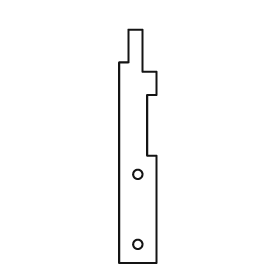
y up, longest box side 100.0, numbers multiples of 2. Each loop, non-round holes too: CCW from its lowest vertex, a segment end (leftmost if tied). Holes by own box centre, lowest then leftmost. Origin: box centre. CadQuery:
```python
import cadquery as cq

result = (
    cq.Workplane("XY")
    .moveTo(-8.0, -50.0)
    .lineTo(8.0, -50.0)
    .lineTo(8.0, -4.0)
    .lineTo(4.0, -4.0)
    .lineTo(4.0, 22.0)
    .lineTo(8.0, 22.0)
    .lineTo(8.0, 32.0)
    .lineTo(2.0, 32.0)
    .lineTo(2.0, 50.0)
    .lineTo(-4.0, 50.0)
    .lineTo(-4.0, 36.0)
    .lineTo(-8.0, 36.0)
    .close()
    .moveTo(0.0, -42.0)
    .circle(2.0)
    .moveTo(0.0, -12.0)
    .circle(2.0)
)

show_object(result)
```